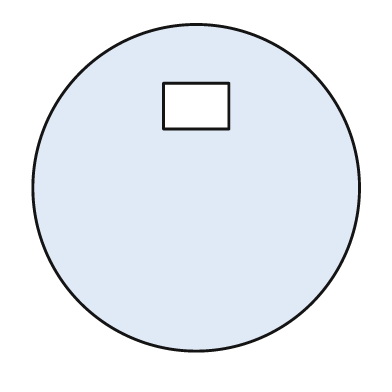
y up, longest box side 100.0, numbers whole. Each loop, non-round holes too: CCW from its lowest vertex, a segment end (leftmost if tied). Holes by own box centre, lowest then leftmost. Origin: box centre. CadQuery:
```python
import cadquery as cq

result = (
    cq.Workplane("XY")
    .moveTo(0.0, 0.0)
    .circle(50.0)
    .moveTo(-10.0, 18.0)
    .lineTo(10.0, 18.0)
    .lineTo(10.0, 32.0)
    .lineTo(-10.0, 32.0)
    .close()
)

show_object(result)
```